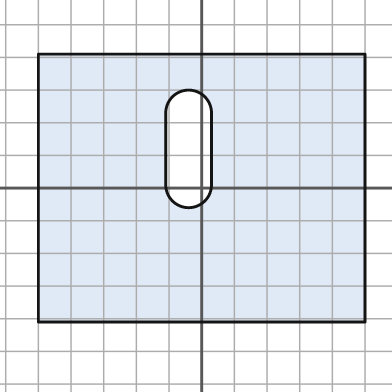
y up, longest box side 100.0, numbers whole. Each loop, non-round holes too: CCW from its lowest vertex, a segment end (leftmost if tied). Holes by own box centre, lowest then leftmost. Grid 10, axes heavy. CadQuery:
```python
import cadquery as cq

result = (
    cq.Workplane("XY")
    .moveTo(-50.0, -41.0)
    .lineTo(50.0, -41.0)
    .lineTo(50.0, 41.0)
    .lineTo(-50.0, 41.0)
    .close()
    .moveTo(-11.0, 1.0)
    .threePointArc((-4.0, -6.0), (3.0, 1.0))
    .lineTo(3.0, 23.0)
    .threePointArc((-4.0, 30.0), (-11.0, 23.0))
    .close()
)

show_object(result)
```